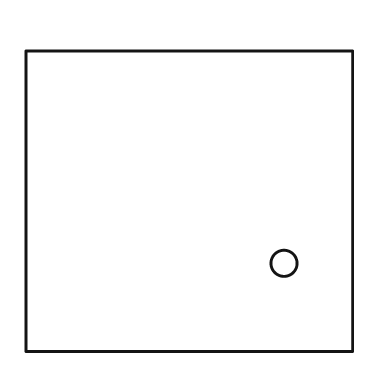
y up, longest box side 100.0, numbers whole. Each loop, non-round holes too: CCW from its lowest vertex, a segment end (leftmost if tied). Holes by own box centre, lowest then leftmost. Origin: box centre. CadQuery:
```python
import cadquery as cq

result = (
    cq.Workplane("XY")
    .moveTo(-50.0, -46.0)
    .lineTo(50.0, -46.0)
    .lineTo(50.0, 46.0)
    .lineTo(-50.0, 46.0)
    .close()
    .moveTo(29.0, -19.0)
    .circle(4.0)
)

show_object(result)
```